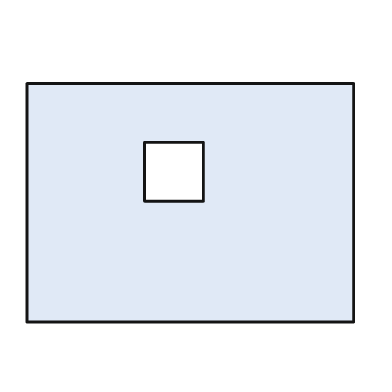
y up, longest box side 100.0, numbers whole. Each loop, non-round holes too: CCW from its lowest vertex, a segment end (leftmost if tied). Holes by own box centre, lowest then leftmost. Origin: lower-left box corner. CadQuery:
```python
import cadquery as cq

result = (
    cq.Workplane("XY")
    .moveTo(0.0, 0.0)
    .lineTo(100.0, 0.0)
    .lineTo(100.0, 73.0)
    .lineTo(0.0, 73.0)
    .close()
    .moveTo(36.0, 37.0)
    .lineTo(54.0, 37.0)
    .lineTo(54.0, 55.0)
    .lineTo(36.0, 55.0)
    .close()
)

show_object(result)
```